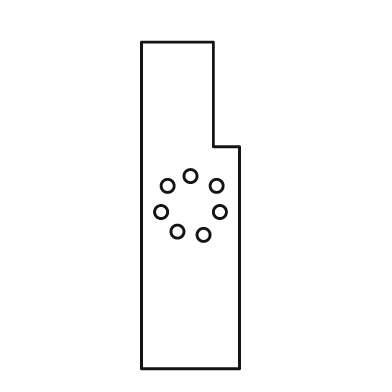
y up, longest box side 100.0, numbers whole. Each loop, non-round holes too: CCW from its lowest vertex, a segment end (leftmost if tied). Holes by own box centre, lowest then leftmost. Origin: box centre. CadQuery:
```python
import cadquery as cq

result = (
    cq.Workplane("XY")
    .moveTo(-15.0, -50.0)
    .lineTo(15.0, -50.0)
    .lineTo(15.0, 18.0)
    .lineTo(7.0, 18.0)
    .lineTo(7.0, 50.0)
    .lineTo(-15.0, 50.0)
    .close()
    .moveTo(4.0, -9.0)
    .circle(2.0)
    .moveTo(-4.0, -8.0)
    .circle(2.0)
    .moveTo(-9.0, -2.0)
    .circle(2.0)
    .moveTo(9.0, -2.0)
    .circle(2.0)
    .moveTo(-7.0, 6.0)
    .circle(2.0)
    .moveTo(8.0, 6.0)
    .circle(2.0)
    .moveTo(0.0, 9.0)
    .circle(2.0)
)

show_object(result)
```